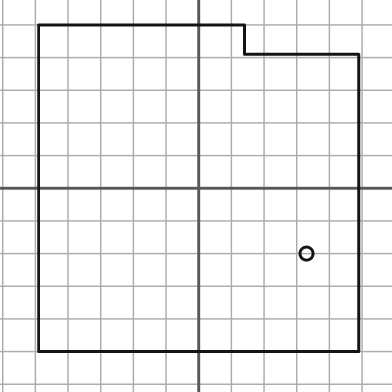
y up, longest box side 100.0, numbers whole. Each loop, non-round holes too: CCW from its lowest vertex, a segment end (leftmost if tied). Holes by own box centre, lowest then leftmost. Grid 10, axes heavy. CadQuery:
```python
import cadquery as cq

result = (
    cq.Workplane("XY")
    .moveTo(-49.0, -50.0)
    .lineTo(49.0, -50.0)
    .lineTo(49.0, 41.0)
    .lineTo(14.0, 41.0)
    .lineTo(14.0, 50.0)
    .lineTo(-49.0, 50.0)
    .close()
    .moveTo(33.0, -20.0)
    .circle(2.0)
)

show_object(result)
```